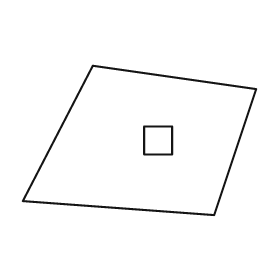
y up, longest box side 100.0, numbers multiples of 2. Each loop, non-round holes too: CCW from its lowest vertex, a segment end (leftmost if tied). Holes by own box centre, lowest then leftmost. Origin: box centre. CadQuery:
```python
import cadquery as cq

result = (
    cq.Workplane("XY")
    .moveTo(32.0, -32.0)
    .lineTo(50.0, 22.0)
    .lineTo(-20.0, 32.0)
    .lineTo(-50.0, -26.0)
    .close()
    .moveTo(2.0, -6.0)
    .lineTo(14.0, -6.0)
    .lineTo(14.0, 6.0)
    .lineTo(2.0, 6.0)
    .close()
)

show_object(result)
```